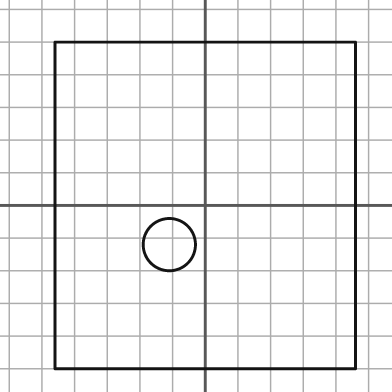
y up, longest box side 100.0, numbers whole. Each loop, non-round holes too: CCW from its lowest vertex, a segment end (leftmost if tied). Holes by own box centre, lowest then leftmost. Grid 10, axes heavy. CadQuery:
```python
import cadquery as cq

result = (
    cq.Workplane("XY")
    .moveTo(-46.0, -50.0)
    .lineTo(46.0, -50.0)
    .lineTo(46.0, 50.0)
    .lineTo(-46.0, 50.0)
    .close()
    .moveTo(-11.0, -12.0)
    .circle(8.0)
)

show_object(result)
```